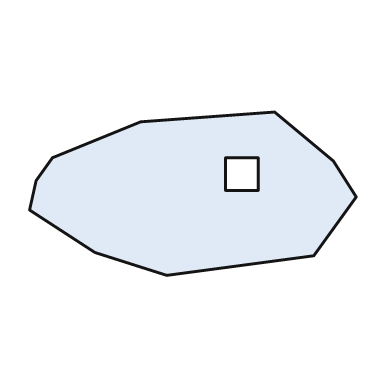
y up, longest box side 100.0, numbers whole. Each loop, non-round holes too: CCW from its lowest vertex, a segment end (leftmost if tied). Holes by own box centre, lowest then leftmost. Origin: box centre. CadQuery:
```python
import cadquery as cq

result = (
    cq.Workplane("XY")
    .moveTo(-8.0, -25.0)
    .lineTo(37.0, -19.0)
    .lineTo(50.0, -1.0)
    .lineTo(43.0, 10.0)
    .lineTo(25.0, 25.0)
    .lineTo(-16.0, 22.0)
    .lineTo(-43.0, 11.0)
    .lineTo(-48.0, 4.0)
    .lineTo(-50.0, -5.0)
    .lineTo(-30.0, -18.0)
    .close()
    .moveTo(10.0, 1.0)
    .lineTo(20.0, 1.0)
    .lineTo(20.0, 11.0)
    .lineTo(10.0, 11.0)
    .close()
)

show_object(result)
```